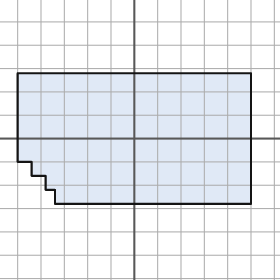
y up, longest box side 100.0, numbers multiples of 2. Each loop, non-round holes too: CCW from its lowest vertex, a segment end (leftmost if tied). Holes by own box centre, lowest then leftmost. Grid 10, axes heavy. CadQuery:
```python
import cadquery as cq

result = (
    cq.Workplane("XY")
    .moveTo(-34.0, -28.0)
    .lineTo(50.0, -28.0)
    .lineTo(50.0, 28.0)
    .lineTo(-50.0, 28.0)
    .lineTo(-50.0, -10.0)
    .lineTo(-44.0, -10.0)
    .lineTo(-44.0, -16.0)
    .lineTo(-38.0, -16.0)
    .lineTo(-38.0, -22.0)
    .lineTo(-34.0, -22.0)
    .close()
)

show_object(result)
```